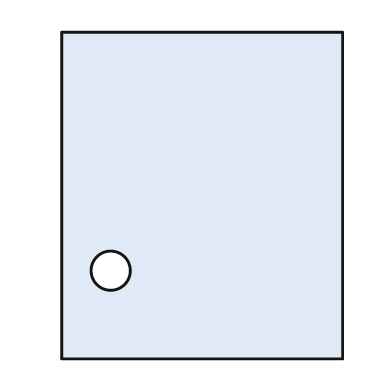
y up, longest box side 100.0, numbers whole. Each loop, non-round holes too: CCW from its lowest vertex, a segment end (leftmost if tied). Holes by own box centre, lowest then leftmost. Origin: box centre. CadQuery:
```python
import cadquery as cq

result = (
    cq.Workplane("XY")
    .moveTo(-43.0, -50.0)
    .lineTo(43.0, -50.0)
    .lineTo(43.0, 50.0)
    .lineTo(-43.0, 50.0)
    .close()
    .moveTo(-28.0, -23.0)
    .circle(6.0)
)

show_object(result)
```